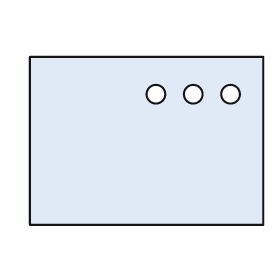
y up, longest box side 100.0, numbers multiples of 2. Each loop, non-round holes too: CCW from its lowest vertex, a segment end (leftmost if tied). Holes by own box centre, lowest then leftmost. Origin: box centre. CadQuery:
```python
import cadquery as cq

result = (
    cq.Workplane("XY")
    .moveTo(-50.0, -36.0)
    .lineTo(50.0, -36.0)
    .lineTo(50.0, 36.0)
    .lineTo(-50.0, 36.0)
    .close()
    .moveTo(4.0, 20.0)
    .circle(4.0)
    .moveTo(20.0, 20.0)
    .circle(4.0)
    .moveTo(36.0, 20.0)
    .circle(4.0)
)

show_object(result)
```